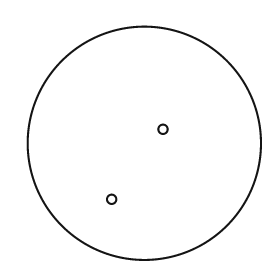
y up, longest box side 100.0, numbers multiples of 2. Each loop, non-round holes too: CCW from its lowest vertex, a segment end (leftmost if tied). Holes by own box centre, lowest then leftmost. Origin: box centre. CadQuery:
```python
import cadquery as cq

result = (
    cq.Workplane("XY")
    .moveTo(0.0, 0.0)
    .circle(50.0)
    .moveTo(-14.0, -24.0)
    .circle(2.0)
    .moveTo(8.0, 6.0)
    .circle(2.0)
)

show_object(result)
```